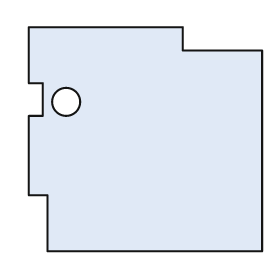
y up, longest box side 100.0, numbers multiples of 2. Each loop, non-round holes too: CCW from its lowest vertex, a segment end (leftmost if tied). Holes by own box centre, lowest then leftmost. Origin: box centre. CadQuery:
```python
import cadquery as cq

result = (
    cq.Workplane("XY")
    .moveTo(-42.0, -48.0)
    .lineTo(50.0, -48.0)
    .lineTo(50.0, 38.0)
    .lineTo(16.0, 38.0)
    .lineTo(16.0, 48.0)
    .lineTo(-50.0, 48.0)
    .lineTo(-50.0, 24.0)
    .lineTo(-44.0, 24.0)
    .lineTo(-44.0, 10.0)
    .lineTo(-50.0, 10.0)
    .lineTo(-50.0, -24.0)
    .lineTo(-42.0, -24.0)
    .close()
    .moveTo(-34.0, 16.0)
    .circle(6.0)
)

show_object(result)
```